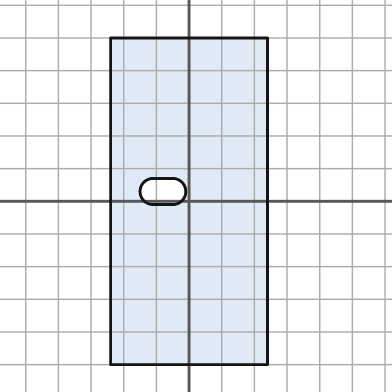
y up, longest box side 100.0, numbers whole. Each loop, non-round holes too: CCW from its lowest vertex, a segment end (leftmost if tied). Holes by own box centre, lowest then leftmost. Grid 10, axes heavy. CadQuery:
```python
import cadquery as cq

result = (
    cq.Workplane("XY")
    .moveTo(-24.0, -50.0)
    .lineTo(24.0, -50.0)
    .lineTo(24.0, 50.0)
    .lineTo(-24.0, 50.0)
    .close()
    .moveTo(-11.0, -1.0)
    .lineTo(-5.0, -1.0)
    .threePointArc((-1.0, 3.0), (-5.0, 7.0))
    .lineTo(-11.0, 7.0)
    .threePointArc((-15.0, 3.0), (-11.0, -1.0))
    .close()
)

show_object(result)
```